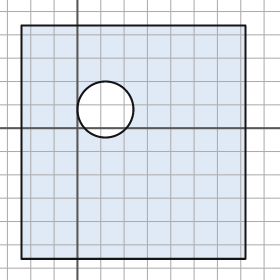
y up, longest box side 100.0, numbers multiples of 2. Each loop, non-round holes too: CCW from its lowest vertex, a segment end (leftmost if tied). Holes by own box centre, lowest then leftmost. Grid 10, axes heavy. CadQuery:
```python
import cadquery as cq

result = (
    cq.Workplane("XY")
    .moveTo(-24.0, -56.0)
    .lineTo(72.0, -56.0)
    .lineTo(72.0, 44.0)
    .lineTo(-24.0, 44.0)
    .close()
    .moveTo(12.0, 8.0)
    .circle(12.0)
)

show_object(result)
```